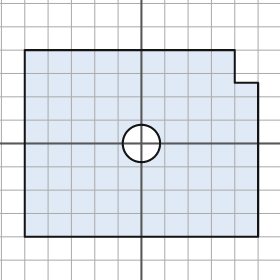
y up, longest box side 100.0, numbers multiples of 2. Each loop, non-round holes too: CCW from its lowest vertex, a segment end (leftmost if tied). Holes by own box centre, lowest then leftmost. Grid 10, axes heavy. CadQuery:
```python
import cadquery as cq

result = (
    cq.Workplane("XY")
    .moveTo(-50.0, -40.0)
    .lineTo(50.0, -40.0)
    .lineTo(50.0, 26.0)
    .lineTo(40.0, 26.0)
    .lineTo(40.0, 40.0)
    .lineTo(-50.0, 40.0)
    .close()
    .moveTo(0.0, 0.0)
    .circle(8.0)
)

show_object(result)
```